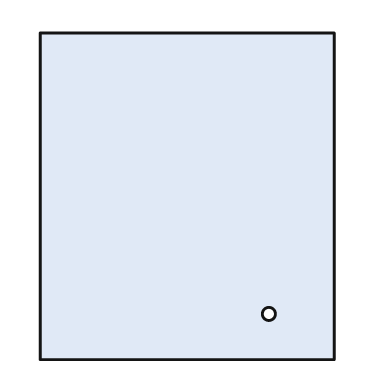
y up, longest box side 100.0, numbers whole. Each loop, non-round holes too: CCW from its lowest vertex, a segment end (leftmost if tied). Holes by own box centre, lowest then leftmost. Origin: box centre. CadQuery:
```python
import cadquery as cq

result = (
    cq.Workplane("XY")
    .moveTo(-45.0, -50.0)
    .lineTo(45.0, -50.0)
    .lineTo(45.0, 50.0)
    .lineTo(-45.0, 50.0)
    .close()
    .moveTo(25.0, -36.0)
    .circle(2.0)
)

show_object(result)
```